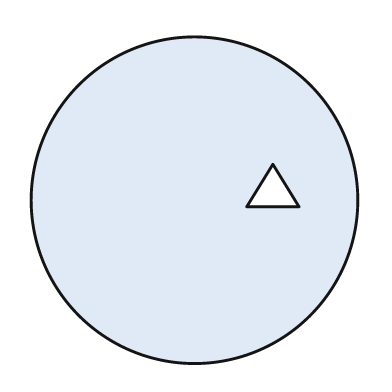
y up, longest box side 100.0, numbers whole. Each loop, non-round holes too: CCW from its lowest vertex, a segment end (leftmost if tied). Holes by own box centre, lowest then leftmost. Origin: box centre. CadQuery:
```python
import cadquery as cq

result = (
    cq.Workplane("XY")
    .moveTo(0.0, 0.0)
    .circle(50.0)
    .moveTo(16.0, -2.0)
    .lineTo(32.0, -2.0)
    .lineTo(24.0, 11.0)
    .close()
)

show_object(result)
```